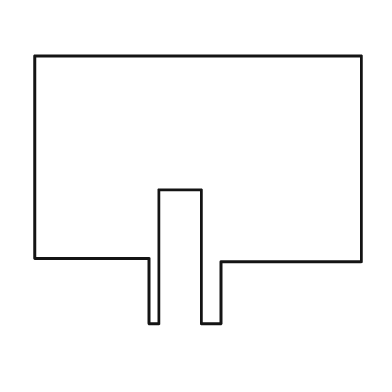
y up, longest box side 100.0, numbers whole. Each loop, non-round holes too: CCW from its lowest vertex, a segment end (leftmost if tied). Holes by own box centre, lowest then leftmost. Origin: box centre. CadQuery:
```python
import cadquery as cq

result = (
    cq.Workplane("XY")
    .moveTo(-15.0, -41.0)
    .lineTo(-12.0, -41.0)
    .lineTo(-12.0, 0.0)
    .lineTo(1.0, 0.0)
    .lineTo(1.0, -41.0)
    .lineTo(7.0, -41.0)
    .lineTo(7.0, -22.0)
    .lineTo(50.0, -22.0)
    .lineTo(50.0, 41.0)
    .lineTo(-50.0, 41.0)
    .lineTo(-50.0, -21.0)
    .lineTo(-15.0, -21.0)
    .close()
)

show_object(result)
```